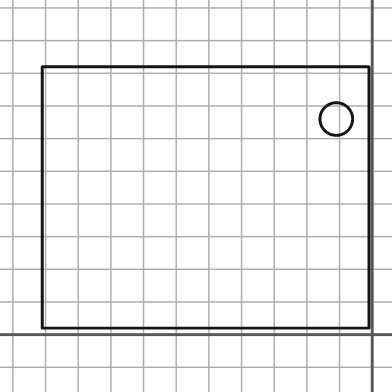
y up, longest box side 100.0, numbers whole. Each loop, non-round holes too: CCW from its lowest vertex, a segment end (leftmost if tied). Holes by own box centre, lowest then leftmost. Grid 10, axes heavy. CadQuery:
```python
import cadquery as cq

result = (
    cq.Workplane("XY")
    .moveTo(-101.0, 2.0)
    .lineTo(-1.0, 2.0)
    .lineTo(-1.0, 82.0)
    .lineTo(-101.0, 82.0)
    .close()
    .moveTo(-11.0, 66.0)
    .circle(5.0)
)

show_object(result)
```